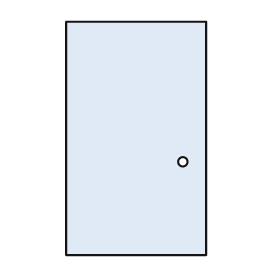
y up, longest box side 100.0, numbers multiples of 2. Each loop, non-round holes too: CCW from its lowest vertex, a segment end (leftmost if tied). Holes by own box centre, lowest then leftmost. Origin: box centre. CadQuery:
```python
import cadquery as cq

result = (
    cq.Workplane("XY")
    .moveTo(-30.0, -50.0)
    .lineTo(30.0, -50.0)
    .lineTo(30.0, 50.0)
    .lineTo(-30.0, 50.0)
    .close()
    .moveTo(20.0, -10.0)
    .circle(2.0)
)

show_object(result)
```